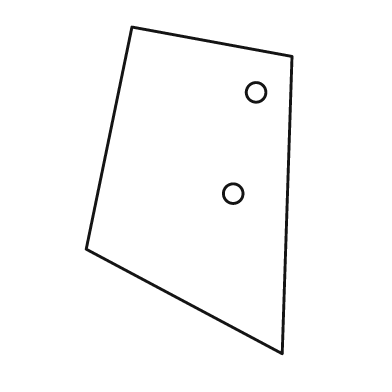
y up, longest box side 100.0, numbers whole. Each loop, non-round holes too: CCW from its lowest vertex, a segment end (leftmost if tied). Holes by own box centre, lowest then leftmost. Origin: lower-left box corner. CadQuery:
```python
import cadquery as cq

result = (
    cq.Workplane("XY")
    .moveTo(60.0, 0.0)
    .lineTo(63.0, 91.0)
    .lineTo(14.0, 100.0)
    .lineTo(0.0, 32.0)
    .close()
    .moveTo(45.0, 49.0)
    .circle(3.0)
    .moveTo(52.0, 80.0)
    .circle(3.0)
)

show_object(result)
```